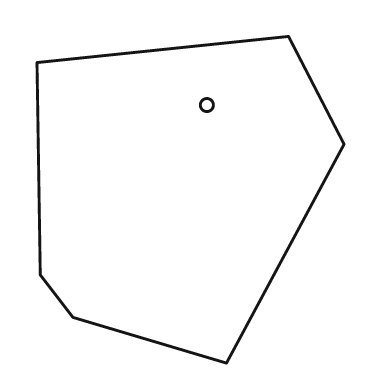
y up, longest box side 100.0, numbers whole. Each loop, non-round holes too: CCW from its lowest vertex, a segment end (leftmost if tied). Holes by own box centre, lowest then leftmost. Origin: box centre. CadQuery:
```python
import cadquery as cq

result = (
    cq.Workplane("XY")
    .moveTo(11.0, -50.0)
    .lineTo(47.0, 17.0)
    .lineTo(30.0, 50.0)
    .lineTo(-47.0, 42.0)
    .lineTo(-46.0, -23.0)
    .lineTo(-36.0, -36.0)
    .close()
    .moveTo(5.0, 29.0)
    .circle(2.0)
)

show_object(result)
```